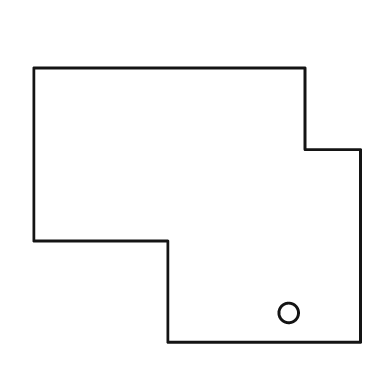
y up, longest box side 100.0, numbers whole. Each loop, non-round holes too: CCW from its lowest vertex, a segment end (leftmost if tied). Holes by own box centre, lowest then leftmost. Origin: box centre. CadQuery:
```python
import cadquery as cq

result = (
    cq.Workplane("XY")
    .moveTo(-9.0, -42.0)
    .lineTo(50.0, -42.0)
    .lineTo(50.0, 17.0)
    .lineTo(33.0, 17.0)
    .lineTo(33.0, 42.0)
    .lineTo(-50.0, 42.0)
    .lineTo(-50.0, -11.0)
    .lineTo(-9.0, -11.0)
    .close()
    .moveTo(28.0, -33.0)
    .circle(3.0)
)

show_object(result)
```